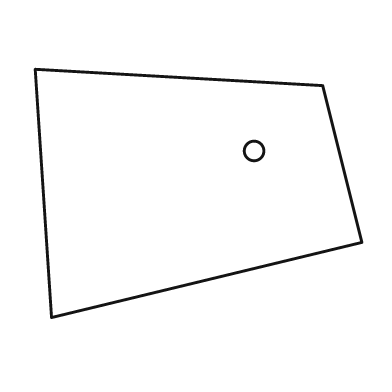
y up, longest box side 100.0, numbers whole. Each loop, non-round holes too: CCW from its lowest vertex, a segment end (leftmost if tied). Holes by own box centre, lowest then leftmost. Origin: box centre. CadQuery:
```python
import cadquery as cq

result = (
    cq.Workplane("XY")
    .moveTo(-45.0, -38.0)
    .lineTo(50.0, -15.0)
    .lineTo(38.0, 33.0)
    .lineTo(-50.0, 38.0)
    .close()
    .moveTo(17.0, 13.0)
    .circle(3.0)
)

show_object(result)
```